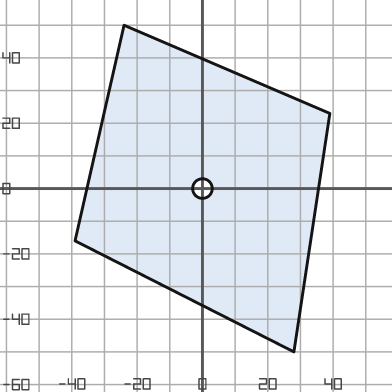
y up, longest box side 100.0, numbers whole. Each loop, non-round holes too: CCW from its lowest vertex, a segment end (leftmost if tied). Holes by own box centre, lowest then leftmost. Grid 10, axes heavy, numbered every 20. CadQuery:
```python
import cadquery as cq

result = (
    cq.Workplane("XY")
    .moveTo(28.0, -50.0)
    .lineTo(39.0, 23.0)
    .lineTo(-24.0, 50.0)
    .lineTo(-39.0, -16.0)
    .close()
    .moveTo(0.0, 0.0)
    .circle(3.0)
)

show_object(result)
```